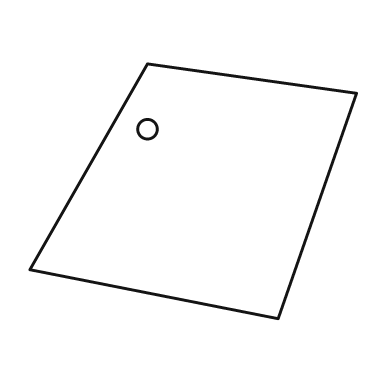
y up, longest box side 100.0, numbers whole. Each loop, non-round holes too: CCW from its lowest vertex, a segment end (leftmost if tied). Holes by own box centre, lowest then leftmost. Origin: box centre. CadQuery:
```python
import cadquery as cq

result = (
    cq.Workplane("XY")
    .moveTo(26.0, -39.0)
    .lineTo(50.0, 30.0)
    .lineTo(-14.0, 39.0)
    .lineTo(-50.0, -24.0)
    .close()
    .moveTo(-14.0, 19.0)
    .circle(3.0)
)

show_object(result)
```